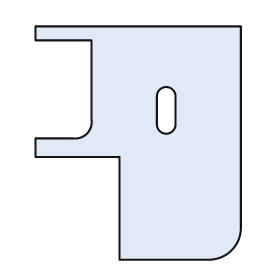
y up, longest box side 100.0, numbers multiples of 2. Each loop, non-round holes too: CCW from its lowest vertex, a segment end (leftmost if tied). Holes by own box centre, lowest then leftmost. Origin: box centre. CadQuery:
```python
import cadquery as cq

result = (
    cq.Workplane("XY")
    .moveTo(-8.0, -50.0)
    .lineTo(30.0, -50.0)
    .threePointArc((40.0, -46.0), (44.0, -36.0))
    .lineTo(44.0, 50.0)
    .lineTo(-44.0, 50.0)
    .lineTo(-44.0, 44.0)
    .lineTo(-20.0, 44.0)
    .lineTo(-20.0, 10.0)
    .threePointArc((-22.0, 4.0), (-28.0, 2.0))
    .lineTo(-44.0, 2.0)
    .lineTo(-44.0, -6.0)
    .lineTo(-8.0, -6.0)
    .close()
    .moveTo(8.0, 8.0)
    .threePointArc((12.0, 4.0), (16.0, 8.0))
    .lineTo(16.0, 20.0)
    .threePointArc((12.0, 24.0), (8.0, 20.0))
    .close()
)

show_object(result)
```